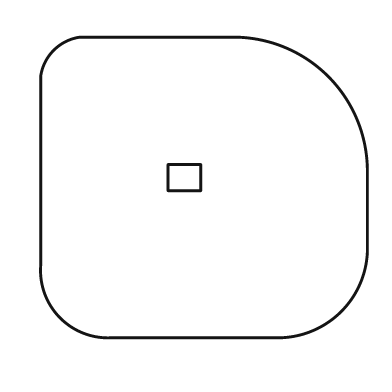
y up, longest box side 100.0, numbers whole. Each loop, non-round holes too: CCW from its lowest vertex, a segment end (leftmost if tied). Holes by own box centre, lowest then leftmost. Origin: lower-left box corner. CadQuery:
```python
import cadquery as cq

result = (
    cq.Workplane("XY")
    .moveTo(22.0, 0.0)
    .lineTo(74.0, 0.0)
    .threePointArc((92.0, 8.0), (100.0, 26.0))
    .lineTo(100.0, 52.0)
    .threePointArc((88.0, 80.0), (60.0, 92.0))
    .lineTo(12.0, 92.0)
    .threePointArc((4.0, 88.0), (0.0, 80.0))
    .lineTo(0.0, 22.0)
    .threePointArc((6.0, 6.0), (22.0, 0.0))
    .close()
    .moveTo(39.0, 45.0)
    .lineTo(49.0, 45.0)
    .lineTo(49.0, 53.0)
    .lineTo(39.0, 53.0)
    .close()
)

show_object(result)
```